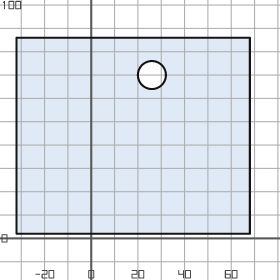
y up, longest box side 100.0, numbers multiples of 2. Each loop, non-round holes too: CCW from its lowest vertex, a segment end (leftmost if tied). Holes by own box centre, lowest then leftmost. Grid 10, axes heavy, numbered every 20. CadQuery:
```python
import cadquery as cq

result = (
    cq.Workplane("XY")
    .moveTo(-32.0, 2.0)
    .lineTo(68.0, 2.0)
    .lineTo(68.0, 86.0)
    .lineTo(-32.0, 86.0)
    .close()
    .moveTo(26.0, 70.0)
    .circle(6.0)
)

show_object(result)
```